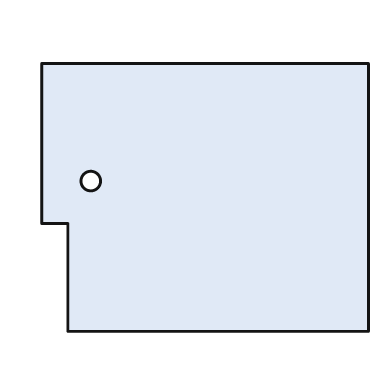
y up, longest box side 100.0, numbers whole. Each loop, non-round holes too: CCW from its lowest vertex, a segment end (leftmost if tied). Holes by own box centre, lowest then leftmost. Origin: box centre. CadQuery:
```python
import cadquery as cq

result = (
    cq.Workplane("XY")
    .moveTo(-42.0, -41.0)
    .lineTo(50.0, -41.0)
    .lineTo(50.0, 41.0)
    .lineTo(-50.0, 41.0)
    .lineTo(-50.0, -8.0)
    .lineTo(-42.0, -8.0)
    .close()
    .moveTo(-35.0, 5.0)
    .circle(3.0)
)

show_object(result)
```